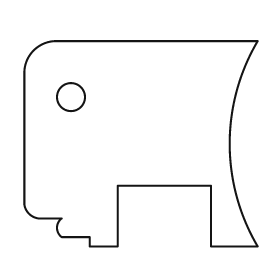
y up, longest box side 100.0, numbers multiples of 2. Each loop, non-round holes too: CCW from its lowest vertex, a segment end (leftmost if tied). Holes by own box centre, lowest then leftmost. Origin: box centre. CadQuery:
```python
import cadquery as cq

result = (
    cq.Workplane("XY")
    .moveTo(-22.0, -44.0)
    .lineTo(-10.0, -44.0)
    .lineTo(-10.0, -18.0)
    .lineTo(30.0, -18.0)
    .lineTo(30.0, -44.0)
    .lineTo(50.0, -44.0)
    .threePointArc((38.0, 0.0), (50.0, 44.0))
    .lineTo(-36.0, 44.0)
    .threePointArc((-46.0, 40.0), (-50.0, 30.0))
    .lineTo(-50.0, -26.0)
    .threePointArc((-48.0, -30.0), (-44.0, -32.0))
    .lineTo(-34.0, -32.0)
    .threePointArc((-36.0, -36.0), (-34.0, -40.0))
    .lineTo(-22.0, -40.0)
    .close()
    .moveTo(-30.0, 20.0)
    .circle(6.0)
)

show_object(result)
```